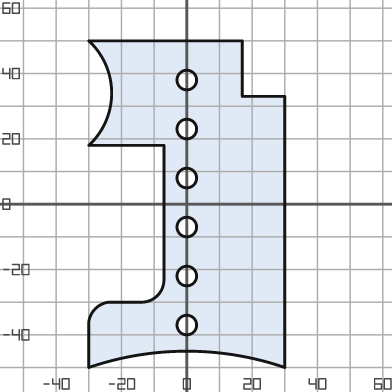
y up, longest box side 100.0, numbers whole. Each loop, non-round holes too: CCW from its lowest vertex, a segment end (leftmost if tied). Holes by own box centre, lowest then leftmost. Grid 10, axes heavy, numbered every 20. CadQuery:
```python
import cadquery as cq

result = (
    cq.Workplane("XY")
    .moveTo(-30.0, -50.0)
    .threePointArc((0.0, -45.0), (30.0, -50.0))
    .lineTo(30.0, 33.0)
    .lineTo(17.0, 33.0)
    .lineTo(17.0, 50.0)
    .lineTo(-30.0, 50.0)
    .threePointArc((-23.0, 34.0), (-30.0, 18.0))
    .lineTo(-7.0, 18.0)
    .lineTo(-7.0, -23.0)
    .threePointArc((-9.0, -28.0), (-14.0, -30.0))
    .lineTo(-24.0, -30.0)
    .threePointArc((-28.0, -32.0), (-30.0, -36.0))
    .close()
    .moveTo(0.0, -37.0)
    .circle(3.0)
    .moveTo(0.0, -22.0)
    .circle(3.0)
    .moveTo(0.0, -7.0)
    .circle(3.0)
    .moveTo(0.0, 8.0)
    .circle(3.0)
    .moveTo(0.0, 23.0)
    .circle(3.0)
    .moveTo(0.0, 38.0)
    .circle(3.0)
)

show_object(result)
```